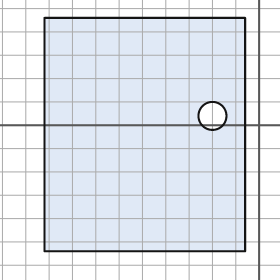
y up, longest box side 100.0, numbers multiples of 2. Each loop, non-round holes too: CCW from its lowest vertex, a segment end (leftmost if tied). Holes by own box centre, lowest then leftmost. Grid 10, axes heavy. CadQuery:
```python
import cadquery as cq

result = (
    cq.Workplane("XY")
    .moveTo(-92.0, -54.0)
    .lineTo(-6.0, -54.0)
    .lineTo(-6.0, 46.0)
    .lineTo(-92.0, 46.0)
    .close()
    .moveTo(-20.0, 4.0)
    .circle(6.0)
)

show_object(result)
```